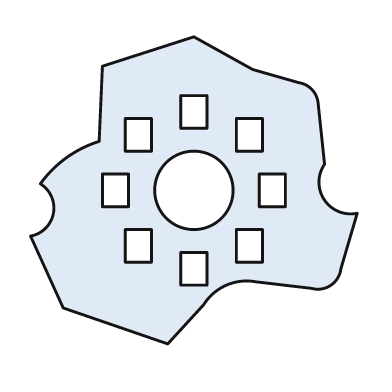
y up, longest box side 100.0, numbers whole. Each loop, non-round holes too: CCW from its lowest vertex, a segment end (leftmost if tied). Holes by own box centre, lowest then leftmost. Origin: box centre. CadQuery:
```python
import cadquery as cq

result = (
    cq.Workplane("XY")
    .moveTo(-8.0, -47.0)
    .lineTo(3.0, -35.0)
    .threePointArc((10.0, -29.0), (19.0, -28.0))
    .lineTo(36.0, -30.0)
    .threePointArc((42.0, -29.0), (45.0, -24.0))
    .lineTo(50.0, -7.0)
    .threePointArc((40.0, -3.0), (40.0, 8.0))
    .lineTo(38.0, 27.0)
    .threePointArc((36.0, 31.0), (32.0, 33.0))
    .lineTo(18.0, 37.0)
    .lineTo(0.0, 47.0)
    .lineTo(-28.0, 38.0)
    .lineTo(-29.0, 15.0)
    .threePointArc((-39.0, 10.0), (-47.0, 2.0))
    .threePointArc((-43.0, -7.0), (-50.0, -14.0))
    .lineTo(-40.0, -36.0)
    .close()
    .moveTo(-4.0, -29.0)
    .lineTo(4.0, -29.0)
    .lineTo(4.0, -19.0)
    .lineTo(-4.0, -19.0)
    .close()
    .moveTo(-21.0, -22.0)
    .lineTo(-13.0, -22.0)
    .lineTo(-13.0, -12.0)
    .lineTo(-21.0, -12.0)
    .close()
    .moveTo(13.0, -22.0)
    .lineTo(21.0, -22.0)
    .lineTo(21.0, -12.0)
    .lineTo(13.0, -12.0)
    .close()
    .moveTo(-28.0, -5.0)
    .lineTo(-20.0, -5.0)
    .lineTo(-20.0, 5.0)
    .lineTo(-28.0, 5.0)
    .close()
    .moveTo(0.0, 0.0)
    .circle(12.0)
    .moveTo(20.0, -5.0)
    .lineTo(28.0, -5.0)
    .lineTo(28.0, 5.0)
    .lineTo(20.0, 5.0)
    .close()
    .moveTo(-21.0, 12.0)
    .lineTo(-13.0, 12.0)
    .lineTo(-13.0, 22.0)
    .lineTo(-21.0, 22.0)
    .close()
    .moveTo(13.0, 12.0)
    .lineTo(21.0, 12.0)
    .lineTo(21.0, 22.0)
    .lineTo(13.0, 22.0)
    .close()
    .moveTo(-4.0, 19.0)
    .lineTo(4.0, 19.0)
    .lineTo(4.0, 29.0)
    .lineTo(-4.0, 29.0)
    .close()
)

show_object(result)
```